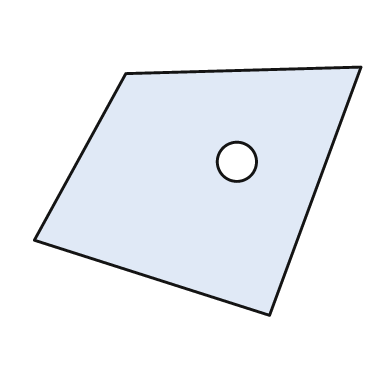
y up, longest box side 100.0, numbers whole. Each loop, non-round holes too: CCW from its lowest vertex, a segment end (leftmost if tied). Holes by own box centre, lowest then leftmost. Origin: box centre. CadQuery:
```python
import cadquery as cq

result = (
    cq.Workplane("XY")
    .moveTo(22.0, -38.0)
    .lineTo(50.0, 38.0)
    .lineTo(-22.0, 36.0)
    .lineTo(-50.0, -15.0)
    .close()
    .moveTo(12.0, 9.0)
    .circle(6.0)
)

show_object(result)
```